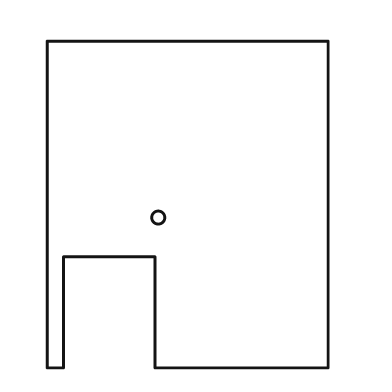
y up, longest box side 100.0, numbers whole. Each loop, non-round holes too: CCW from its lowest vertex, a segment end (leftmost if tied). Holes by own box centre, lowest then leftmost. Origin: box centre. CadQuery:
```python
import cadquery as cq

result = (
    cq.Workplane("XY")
    .moveTo(-43.0, -50.0)
    .lineTo(-38.0, -50.0)
    .lineTo(-38.0, -16.0)
    .lineTo(-10.0, -16.0)
    .lineTo(-10.0, -50.0)
    .lineTo(43.0, -50.0)
    .lineTo(43.0, 50.0)
    .lineTo(-43.0, 50.0)
    .close()
    .moveTo(-9.0, -4.0)
    .circle(2.0)
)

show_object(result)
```